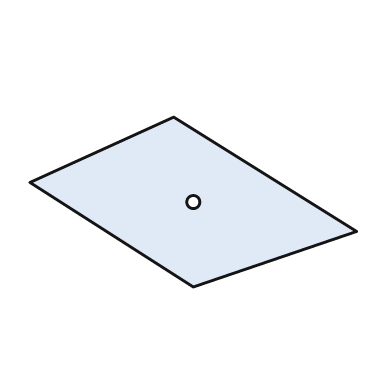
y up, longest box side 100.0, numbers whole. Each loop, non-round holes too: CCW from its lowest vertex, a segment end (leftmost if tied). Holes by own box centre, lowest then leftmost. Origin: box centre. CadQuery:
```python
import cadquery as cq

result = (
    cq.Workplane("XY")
    .moveTo(0.0, -26.0)
    .lineTo(50.0, -9.0)
    .lineTo(-6.0, 26.0)
    .lineTo(-50.0, 6.0)
    .close()
    .moveTo(0.0, 0.0)
    .circle(2.0)
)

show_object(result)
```